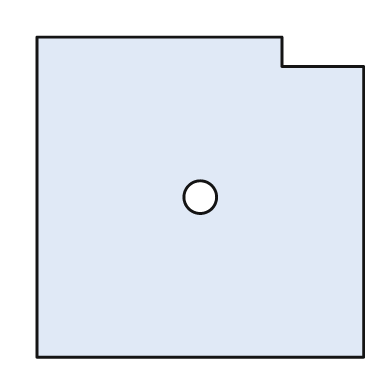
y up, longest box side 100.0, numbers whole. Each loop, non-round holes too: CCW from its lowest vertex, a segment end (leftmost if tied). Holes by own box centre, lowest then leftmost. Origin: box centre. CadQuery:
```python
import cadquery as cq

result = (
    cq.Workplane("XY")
    .moveTo(-50.0, -49.0)
    .lineTo(50.0, -49.0)
    .lineTo(50.0, 40.0)
    .lineTo(25.0, 40.0)
    .lineTo(25.0, 49.0)
    .lineTo(-50.0, 49.0)
    .close()
    .moveTo(0.0, 0.0)
    .circle(5.0)
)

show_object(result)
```